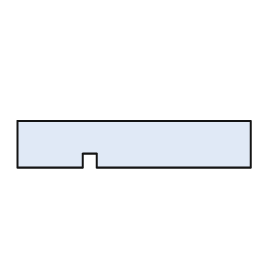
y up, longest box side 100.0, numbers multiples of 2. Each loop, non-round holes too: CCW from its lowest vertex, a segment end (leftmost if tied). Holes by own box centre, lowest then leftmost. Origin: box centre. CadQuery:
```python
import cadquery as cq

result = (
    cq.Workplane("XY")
    .moveTo(-50.0, -10.0)
    .lineTo(-22.0, -10.0)
    .lineTo(-22.0, -4.0)
    .lineTo(-16.0, -4.0)
    .lineTo(-16.0, -10.0)
    .lineTo(50.0, -10.0)
    .lineTo(50.0, 10.0)
    .lineTo(-50.0, 10.0)
    .close()
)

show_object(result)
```